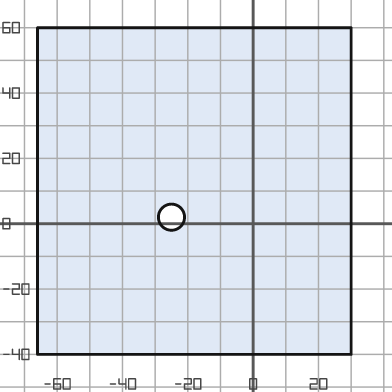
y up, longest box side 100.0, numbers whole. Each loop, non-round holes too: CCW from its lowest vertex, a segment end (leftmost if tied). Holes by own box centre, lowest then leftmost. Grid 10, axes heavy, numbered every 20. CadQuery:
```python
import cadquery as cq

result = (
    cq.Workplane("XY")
    .moveTo(-66.0, -40.0)
    .lineTo(30.0, -40.0)
    .lineTo(30.0, 60.0)
    .lineTo(-66.0, 60.0)
    .close()
    .moveTo(-25.0, 2.0)
    .circle(4.0)
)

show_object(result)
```